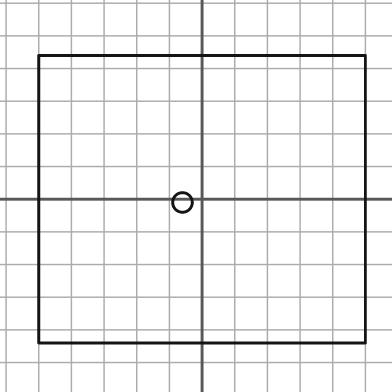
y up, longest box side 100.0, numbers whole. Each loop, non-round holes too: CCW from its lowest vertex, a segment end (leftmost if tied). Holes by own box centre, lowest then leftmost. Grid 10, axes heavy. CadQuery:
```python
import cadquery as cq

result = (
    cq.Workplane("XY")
    .moveTo(-50.0, -44.0)
    .lineTo(50.0, -44.0)
    .lineTo(50.0, 44.0)
    .lineTo(-50.0, 44.0)
    .close()
    .moveTo(-6.0, -1.0)
    .circle(3.0)
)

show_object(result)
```